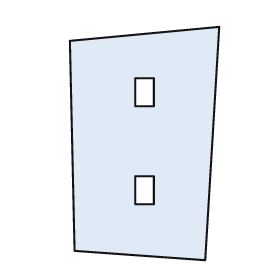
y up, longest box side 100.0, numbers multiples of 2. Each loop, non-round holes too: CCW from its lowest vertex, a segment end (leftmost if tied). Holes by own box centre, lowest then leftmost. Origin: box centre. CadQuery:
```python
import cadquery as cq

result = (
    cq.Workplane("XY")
    .moveTo(26.0, -50.0)
    .lineTo(32.0, 50.0)
    .lineTo(-32.0, 44.0)
    .lineTo(-30.0, -46.0)
    .close()
    .moveTo(-4.0, -26.0)
    .lineTo(4.0, -26.0)
    .lineTo(4.0, -14.0)
    .lineTo(-4.0, -14.0)
    .close()
    .moveTo(-4.0, 16.0)
    .lineTo(4.0, 16.0)
    .lineTo(4.0, 28.0)
    .lineTo(-4.0, 28.0)
    .close()
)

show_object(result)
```